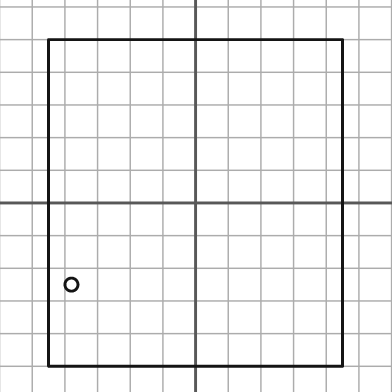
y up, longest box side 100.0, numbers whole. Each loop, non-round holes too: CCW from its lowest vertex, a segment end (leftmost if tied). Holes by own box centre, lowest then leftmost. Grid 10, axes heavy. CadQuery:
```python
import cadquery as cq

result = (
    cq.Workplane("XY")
    .moveTo(-45.0, -50.0)
    .lineTo(45.0, -50.0)
    .lineTo(45.0, 50.0)
    .lineTo(-45.0, 50.0)
    .close()
    .moveTo(-38.0, -25.0)
    .circle(2.0)
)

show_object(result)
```